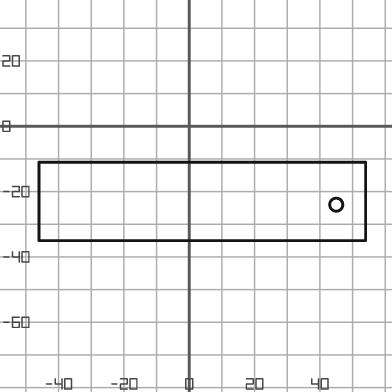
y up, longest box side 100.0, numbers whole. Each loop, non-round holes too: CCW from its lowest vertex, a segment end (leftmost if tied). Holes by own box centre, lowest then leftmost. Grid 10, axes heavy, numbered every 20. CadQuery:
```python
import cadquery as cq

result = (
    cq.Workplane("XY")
    .moveTo(-46.0, -35.0)
    .lineTo(54.0, -35.0)
    .lineTo(54.0, -11.0)
    .lineTo(-46.0, -11.0)
    .close()
    .moveTo(45.0, -24.0)
    .circle(2.0)
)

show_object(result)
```